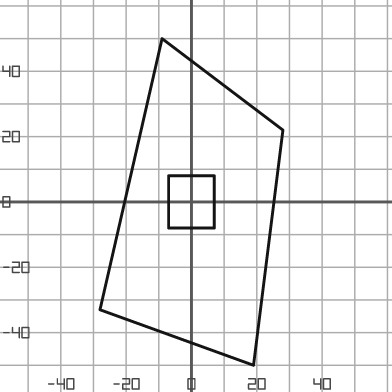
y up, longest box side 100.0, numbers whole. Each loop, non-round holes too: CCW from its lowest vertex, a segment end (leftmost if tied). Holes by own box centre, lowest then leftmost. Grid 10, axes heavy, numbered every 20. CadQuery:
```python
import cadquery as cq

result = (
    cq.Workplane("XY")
    .moveTo(19.0, -50.0)
    .lineTo(28.0, 22.0)
    .lineTo(-9.0, 50.0)
    .lineTo(-28.0, -33.0)
    .close()
    .moveTo(-7.0, -8.0)
    .lineTo(7.0, -8.0)
    .lineTo(7.0, 8.0)
    .lineTo(-7.0, 8.0)
    .close()
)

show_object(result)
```